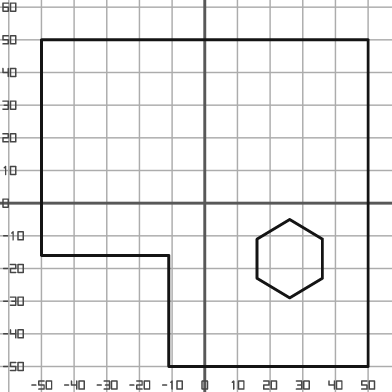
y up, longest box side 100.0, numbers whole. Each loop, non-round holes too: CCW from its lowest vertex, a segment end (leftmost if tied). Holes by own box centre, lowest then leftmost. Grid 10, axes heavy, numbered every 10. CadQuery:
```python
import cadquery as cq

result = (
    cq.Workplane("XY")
    .moveTo(-11.0, -50.0)
    .lineTo(50.0, -50.0)
    .lineTo(50.0, 50.0)
    .lineTo(-50.0, 50.0)
    .lineTo(-50.0, -16.0)
    .lineTo(-11.0, -16.0)
    .close()
    .moveTo(26.0, -29.0)
    .lineTo(36.0, -23.0)
    .lineTo(36.0, -11.0)
    .lineTo(26.0, -5.0)
    .lineTo(16.0, -11.0)
    .lineTo(16.0, -23.0)
    .close()
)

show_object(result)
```